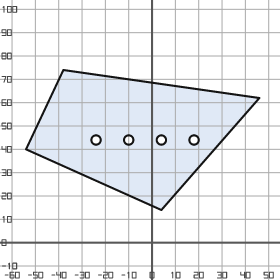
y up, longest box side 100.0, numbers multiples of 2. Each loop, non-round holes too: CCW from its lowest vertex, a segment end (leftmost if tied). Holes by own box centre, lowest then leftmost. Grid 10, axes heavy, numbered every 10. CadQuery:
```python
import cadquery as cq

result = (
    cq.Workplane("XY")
    .moveTo(4.0, 14.0)
    .lineTo(46.0, 62.0)
    .lineTo(-38.0, 74.0)
    .lineTo(-54.0, 40.0)
    .close()
    .moveTo(-24.0, 44.0)
    .circle(2.0)
    .moveTo(-10.0, 44.0)
    .circle(2.0)
    .moveTo(4.0, 44.0)
    .circle(2.0)
    .moveTo(18.0, 44.0)
    .circle(2.0)
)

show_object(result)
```